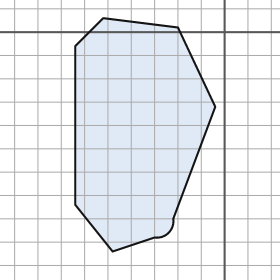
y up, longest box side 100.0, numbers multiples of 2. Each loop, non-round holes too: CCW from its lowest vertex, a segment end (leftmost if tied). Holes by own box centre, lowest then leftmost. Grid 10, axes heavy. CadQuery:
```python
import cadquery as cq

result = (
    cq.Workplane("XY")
    .moveTo(-48.0, -94.0)
    .lineTo(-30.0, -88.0)
    .threePointArc((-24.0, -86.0), (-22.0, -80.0))
    .lineTo(-4.0, -32.0)
    .lineTo(-20.0, 2.0)
    .lineTo(-52.0, 6.0)
    .lineTo(-64.0, -6.0)
    .lineTo(-64.0, -74.0)
    .close()
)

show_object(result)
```